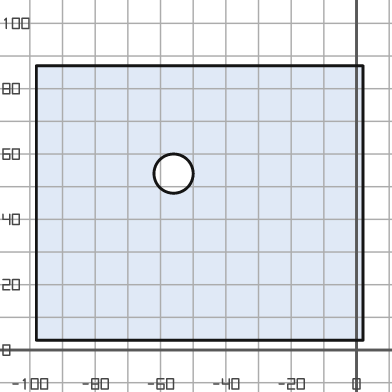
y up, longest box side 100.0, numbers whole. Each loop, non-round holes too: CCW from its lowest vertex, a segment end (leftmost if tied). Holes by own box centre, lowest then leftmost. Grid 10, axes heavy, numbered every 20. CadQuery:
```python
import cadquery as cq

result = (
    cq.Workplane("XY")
    .moveTo(-98.0, 3.0)
    .lineTo(2.0, 3.0)
    .lineTo(2.0, 87.0)
    .lineTo(-98.0, 87.0)
    .close()
    .moveTo(-56.0, 54.0)
    .circle(6.0)
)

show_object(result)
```